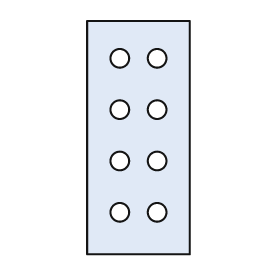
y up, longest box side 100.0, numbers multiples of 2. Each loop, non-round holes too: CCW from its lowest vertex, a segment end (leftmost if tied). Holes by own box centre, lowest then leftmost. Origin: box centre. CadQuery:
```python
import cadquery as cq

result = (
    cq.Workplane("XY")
    .moveTo(-22.0, -50.0)
    .lineTo(22.0, -50.0)
    .lineTo(22.0, 50.0)
    .lineTo(-22.0, 50.0)
    .close()
    .moveTo(-8.0, -32.0)
    .circle(4.0)
    .moveTo(8.0, -32.0)
    .circle(4.0)
    .moveTo(-8.0, -10.0)
    .circle(4.0)
    .moveTo(8.0, -10.0)
    .circle(4.0)
    .moveTo(-8.0, 12.0)
    .circle(4.0)
    .moveTo(8.0, 12.0)
    .circle(4.0)
    .moveTo(-8.0, 34.0)
    .circle(4.0)
    .moveTo(8.0, 34.0)
    .circle(4.0)
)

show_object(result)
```